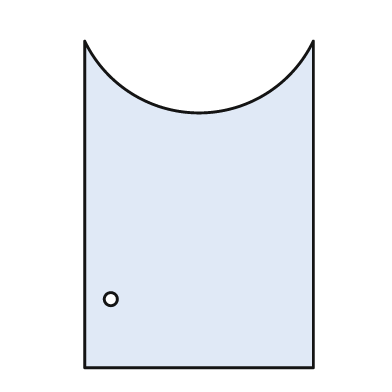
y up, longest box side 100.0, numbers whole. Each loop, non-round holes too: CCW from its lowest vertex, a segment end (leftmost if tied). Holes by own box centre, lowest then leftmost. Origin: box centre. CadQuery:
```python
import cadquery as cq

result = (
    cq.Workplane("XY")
    .moveTo(-35.0, -50.0)
    .lineTo(35.0, -50.0)
    .lineTo(35.0, 50.0)
    .threePointArc((0.0, 28.0), (-35.0, 50.0))
    .close()
    .moveTo(-27.0, -29.0)
    .circle(2.0)
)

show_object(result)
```